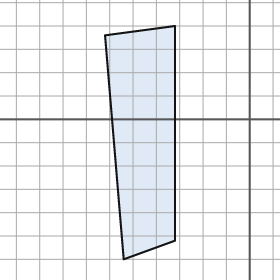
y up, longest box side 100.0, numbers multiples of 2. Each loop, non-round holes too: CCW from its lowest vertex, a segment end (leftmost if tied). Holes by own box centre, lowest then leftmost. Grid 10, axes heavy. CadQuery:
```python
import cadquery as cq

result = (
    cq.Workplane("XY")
    .moveTo(-54.0, -60.0)
    .lineTo(-32.0, -52.0)
    .lineTo(-32.0, 40.0)
    .lineTo(-62.0, 36.0)
    .close()
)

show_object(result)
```